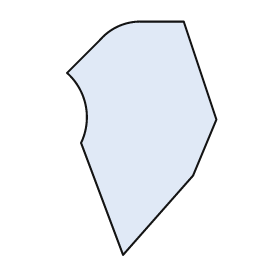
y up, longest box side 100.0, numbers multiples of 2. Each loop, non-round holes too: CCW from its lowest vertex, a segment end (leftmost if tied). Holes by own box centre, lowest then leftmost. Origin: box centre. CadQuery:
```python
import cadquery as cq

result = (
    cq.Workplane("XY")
    .moveTo(-8.0, -50.0)
    .lineTo(22.0, -16.0)
    .lineTo(32.0, 8.0)
    .lineTo(18.0, 50.0)
    .lineTo(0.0, 50.0)
    .threePointArc((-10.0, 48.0), (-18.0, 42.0))
    .lineTo(-32.0, 28.0)
    .threePointArc((-24.0, 14.0), (-26.0, -2.0))
    .close()
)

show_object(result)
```